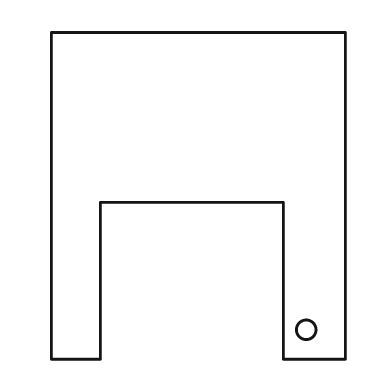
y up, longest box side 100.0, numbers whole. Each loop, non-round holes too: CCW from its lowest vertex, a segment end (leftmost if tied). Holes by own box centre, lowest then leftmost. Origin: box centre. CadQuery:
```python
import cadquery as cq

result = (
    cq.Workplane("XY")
    .moveTo(-45.0, -50.0)
    .lineTo(-30.0, -50.0)
    .lineTo(-30.0, -2.0)
    .lineTo(26.0, -2.0)
    .lineTo(26.0, -50.0)
    .lineTo(45.0, -50.0)
    .lineTo(45.0, 50.0)
    .lineTo(-45.0, 50.0)
    .close()
    .moveTo(33.0, -41.0)
    .circle(3.0)
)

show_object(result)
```